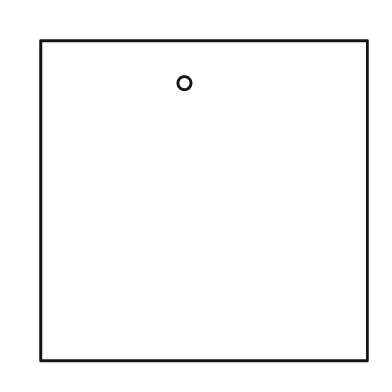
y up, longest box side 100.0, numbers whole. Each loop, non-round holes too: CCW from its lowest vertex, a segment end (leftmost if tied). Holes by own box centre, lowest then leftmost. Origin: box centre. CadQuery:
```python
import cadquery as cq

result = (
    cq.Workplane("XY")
    .moveTo(-50.0, -49.0)
    .lineTo(50.0, -49.0)
    .lineTo(50.0, 49.0)
    .lineTo(-50.0, 49.0)
    .close()
    .moveTo(-6.0, 36.0)
    .circle(2.0)
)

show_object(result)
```